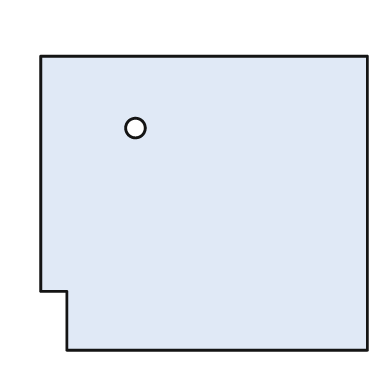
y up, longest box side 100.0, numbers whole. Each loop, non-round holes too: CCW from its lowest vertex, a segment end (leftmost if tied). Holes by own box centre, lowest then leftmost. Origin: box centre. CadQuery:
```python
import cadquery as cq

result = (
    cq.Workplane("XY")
    .moveTo(-42.0, -45.0)
    .lineTo(50.0, -45.0)
    .lineTo(50.0, 45.0)
    .lineTo(-50.0, 45.0)
    .lineTo(-50.0, -27.0)
    .lineTo(-42.0, -27.0)
    .close()
    .moveTo(-21.0, 23.0)
    .circle(3.0)
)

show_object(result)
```